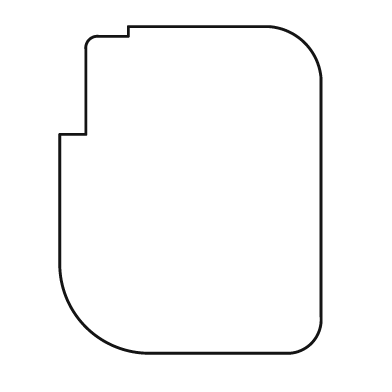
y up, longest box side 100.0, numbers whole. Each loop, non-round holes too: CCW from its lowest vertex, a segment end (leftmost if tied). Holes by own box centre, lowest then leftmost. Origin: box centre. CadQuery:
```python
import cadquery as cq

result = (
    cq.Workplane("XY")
    .moveTo(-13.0, -50.0)
    .lineTo(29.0, -50.0)
    .threePointArc((37.0, -47.0), (40.0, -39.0))
    .lineTo(40.0, 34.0)
    .threePointArc((35.0, 45.0), (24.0, 50.0))
    .lineTo(-19.0, 50.0)
    .lineTo(-19.0, 47.0)
    .lineTo(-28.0, 47.0)
    .threePointArc((-31.0, 46.0), (-32.0, 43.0))
    .lineTo(-32.0, 17.0)
    .lineTo(-40.0, 17.0)
    .lineTo(-40.0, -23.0)
    .threePointArc((-32.0, -42.0), (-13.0, -50.0))
    .close()
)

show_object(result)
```